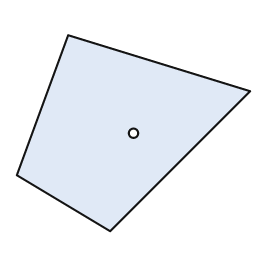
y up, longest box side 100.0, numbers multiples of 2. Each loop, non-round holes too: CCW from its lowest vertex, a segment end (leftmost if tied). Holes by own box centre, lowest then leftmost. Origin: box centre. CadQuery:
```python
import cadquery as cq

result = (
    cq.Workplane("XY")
    .moveTo(-10.0, -42.0)
    .lineTo(50.0, 18.0)
    .lineTo(-28.0, 42.0)
    .lineTo(-50.0, -18.0)
    .close()
    .moveTo(0.0, 0.0)
    .circle(2.0)
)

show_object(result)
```